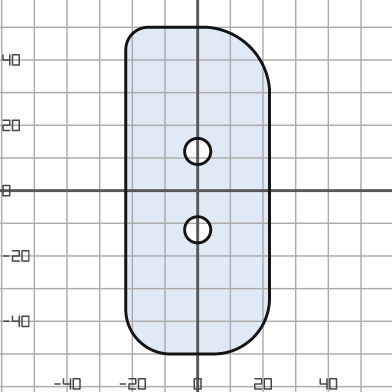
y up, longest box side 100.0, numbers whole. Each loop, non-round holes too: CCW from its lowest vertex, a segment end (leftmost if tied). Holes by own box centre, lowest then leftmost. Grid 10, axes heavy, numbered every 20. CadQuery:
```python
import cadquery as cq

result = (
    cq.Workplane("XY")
    .moveTo(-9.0, -50.0)
    .lineTo(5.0, -50.0)
    .threePointArc((17.0, -45.0), (22.0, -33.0))
    .lineTo(22.0, 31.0)
    .threePointArc((16.0, 44.0), (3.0, 50.0))
    .lineTo(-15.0, 50.0)
    .threePointArc((-20.0, 48.0), (-22.0, 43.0))
    .lineTo(-22.0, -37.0)
    .threePointArc((-18.0, -46.0), (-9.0, -50.0))
    .close()
    .moveTo(0.0, -12.0)
    .circle(4.0)
    .moveTo(0.0, 12.0)
    .circle(4.0)
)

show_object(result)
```